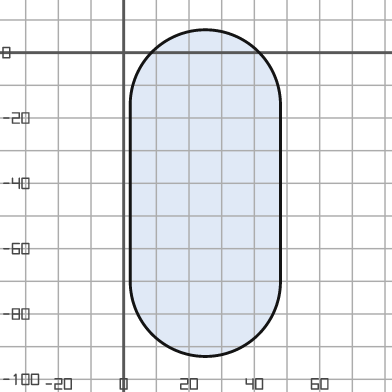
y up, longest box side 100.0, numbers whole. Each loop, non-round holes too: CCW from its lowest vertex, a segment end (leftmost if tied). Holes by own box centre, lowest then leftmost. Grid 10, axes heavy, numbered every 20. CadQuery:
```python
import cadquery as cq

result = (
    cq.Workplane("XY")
    .moveTo(2.0, -70.0)
    .threePointArc((25.0, -93.0), (48.0, -70.0))
    .lineTo(48.0, -16.0)
    .threePointArc((25.0, 7.0), (2.0, -16.0))
    .close()
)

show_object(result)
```